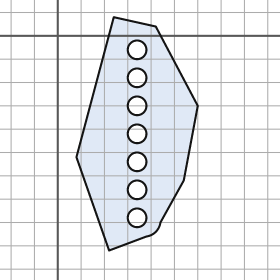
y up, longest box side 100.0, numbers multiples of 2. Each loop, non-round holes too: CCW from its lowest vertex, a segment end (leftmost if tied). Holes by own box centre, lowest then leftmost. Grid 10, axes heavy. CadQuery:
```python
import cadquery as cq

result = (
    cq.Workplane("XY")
    .moveTo(22.0, -92.0)
    .lineTo(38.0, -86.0)
    .threePointArc((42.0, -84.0), (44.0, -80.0))
    .lineTo(54.0, -62.0)
    .lineTo(60.0, -30.0)
    .lineTo(42.0, 4.0)
    .lineTo(24.0, 8.0)
    .lineTo(8.0, -52.0)
    .close()
    .moveTo(34.0, -78.0)
    .circle(4.0)
    .moveTo(34.0, -66.0)
    .circle(4.0)
    .moveTo(34.0, -54.0)
    .circle(4.0)
    .moveTo(34.0, -42.0)
    .circle(4.0)
    .moveTo(34.0, -30.0)
    .circle(4.0)
    .moveTo(34.0, -18.0)
    .circle(4.0)
    .moveTo(34.0, -6.0)
    .circle(4.0)
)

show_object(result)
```